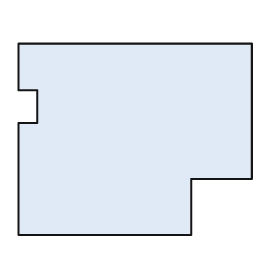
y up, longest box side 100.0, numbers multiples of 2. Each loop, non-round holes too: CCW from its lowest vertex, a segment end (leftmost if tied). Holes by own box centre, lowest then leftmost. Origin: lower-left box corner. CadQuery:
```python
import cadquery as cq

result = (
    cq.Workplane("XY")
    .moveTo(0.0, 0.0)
    .lineTo(74.0, 0.0)
    .lineTo(74.0, 24.0)
    .lineTo(100.0, 24.0)
    .lineTo(100.0, 82.0)
    .lineTo(0.0, 82.0)
    .lineTo(0.0, 62.0)
    .lineTo(8.0, 62.0)
    .lineTo(8.0, 48.0)
    .lineTo(0.0, 48.0)
    .close()
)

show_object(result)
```